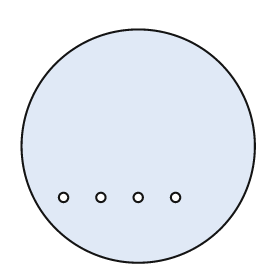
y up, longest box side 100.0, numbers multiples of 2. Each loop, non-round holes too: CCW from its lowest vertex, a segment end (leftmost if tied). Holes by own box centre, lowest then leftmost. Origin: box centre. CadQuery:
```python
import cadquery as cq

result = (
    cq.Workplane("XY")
    .moveTo(0.0, 0.0)
    .circle(50.0)
    .moveTo(-32.0, -22.0)
    .circle(2.0)
    .moveTo(-16.0, -22.0)
    .circle(2.0)
    .moveTo(0.0, -22.0)
    .circle(2.0)
    .moveTo(16.0, -22.0)
    .circle(2.0)
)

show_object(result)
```